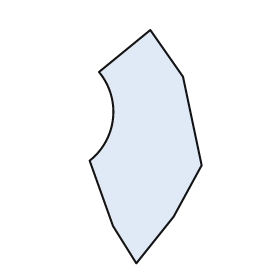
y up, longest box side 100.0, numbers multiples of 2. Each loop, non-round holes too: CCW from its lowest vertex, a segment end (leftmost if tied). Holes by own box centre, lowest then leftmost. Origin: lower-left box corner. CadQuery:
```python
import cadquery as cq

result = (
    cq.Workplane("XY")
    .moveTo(20.0, 0.0)
    .lineTo(36.0, 20.0)
    .lineTo(48.0, 42.0)
    .lineTo(40.0, 80.0)
    .lineTo(26.0, 100.0)
    .lineTo(4.0, 82.0)
    .threePointArc((10.0, 62.0), (0.0, 44.0))
    .lineTo(10.0, 16.0)
    .close()
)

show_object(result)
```